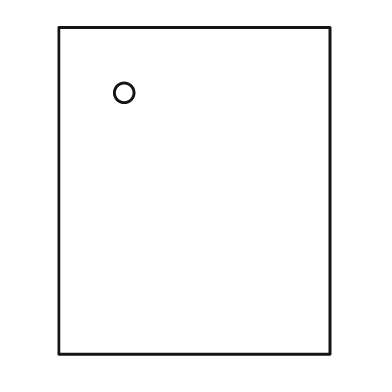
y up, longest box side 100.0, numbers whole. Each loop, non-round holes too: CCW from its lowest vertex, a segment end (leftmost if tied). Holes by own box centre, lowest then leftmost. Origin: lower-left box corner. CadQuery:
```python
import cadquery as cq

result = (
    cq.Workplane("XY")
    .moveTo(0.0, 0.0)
    .lineTo(83.0, 0.0)
    .lineTo(83.0, 100.0)
    .lineTo(0.0, 100.0)
    .close()
    .moveTo(20.0, 80.0)
    .circle(3.0)
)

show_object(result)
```